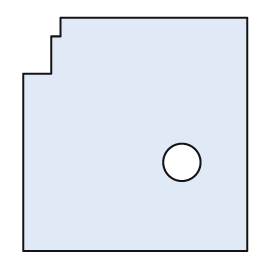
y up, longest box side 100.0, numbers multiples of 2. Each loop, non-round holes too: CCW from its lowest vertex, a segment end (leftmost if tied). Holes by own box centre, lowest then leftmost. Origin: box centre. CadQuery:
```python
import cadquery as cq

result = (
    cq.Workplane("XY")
    .moveTo(-48.0, -50.0)
    .lineTo(48.0, -50.0)
    .lineTo(48.0, 50.0)
    .lineTo(-32.0, 50.0)
    .lineTo(-32.0, 42.0)
    .lineTo(-36.0, 42.0)
    .lineTo(-36.0, 26.0)
    .lineTo(-48.0, 26.0)
    .close()
    .moveTo(20.0, -12.0)
    .circle(8.0)
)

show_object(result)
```